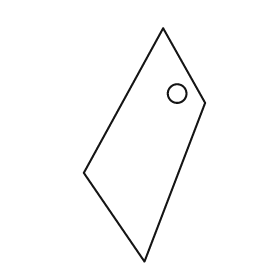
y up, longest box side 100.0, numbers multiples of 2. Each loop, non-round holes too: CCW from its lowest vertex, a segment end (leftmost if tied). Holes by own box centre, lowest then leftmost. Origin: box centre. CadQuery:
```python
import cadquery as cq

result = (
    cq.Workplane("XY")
    .moveTo(0.0, -50.0)
    .lineTo(26.0, 18.0)
    .lineTo(8.0, 50.0)
    .lineTo(-26.0, -12.0)
    .close()
    .moveTo(14.0, 22.0)
    .circle(4.0)
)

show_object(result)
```